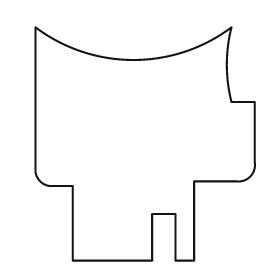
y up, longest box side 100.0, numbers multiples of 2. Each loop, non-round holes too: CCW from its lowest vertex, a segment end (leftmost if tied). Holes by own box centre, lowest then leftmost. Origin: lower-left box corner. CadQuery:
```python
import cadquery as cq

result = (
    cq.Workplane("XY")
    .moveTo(16.0, 0.0)
    .lineTo(50.0, 0.0)
    .lineTo(50.0, 20.0)
    .lineTo(60.0, 20.0)
    .lineTo(60.0, 0.0)
    .lineTo(68.0, 0.0)
    .lineTo(68.0, 34.0)
    .lineTo(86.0, 34.0)
    .threePointArc((92.0, 36.0), (94.0, 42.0))
    .lineTo(94.0, 68.0)
    .lineTo(84.0, 68.0)
    .threePointArc((82.0, 84.0), (84.0, 100.0))
    .threePointArc((42.0, 86.0), (0.0, 100.0))
    .lineTo(0.0, 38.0)
    .threePointArc((2.0, 34.0), (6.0, 32.0))
    .lineTo(16.0, 32.0)
    .close()
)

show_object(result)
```